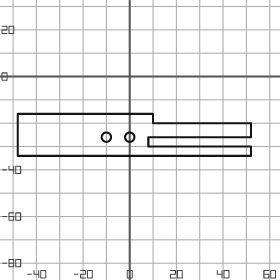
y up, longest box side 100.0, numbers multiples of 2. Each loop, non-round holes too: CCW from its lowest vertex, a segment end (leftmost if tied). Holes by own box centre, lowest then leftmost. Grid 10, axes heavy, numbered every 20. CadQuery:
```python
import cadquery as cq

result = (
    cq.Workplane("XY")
    .moveTo(-48.0, -34.0)
    .lineTo(52.0, -34.0)
    .lineTo(52.0, -30.0)
    .lineTo(8.0, -30.0)
    .lineTo(8.0, -26.0)
    .lineTo(52.0, -26.0)
    .lineTo(52.0, -20.0)
    .lineTo(10.0, -20.0)
    .lineTo(10.0, -16.0)
    .lineTo(-48.0, -16.0)
    .close()
    .moveTo(-10.0, -26.0)
    .circle(2.0)
    .moveTo(0.0, -26.0)
    .circle(2.0)
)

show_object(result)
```